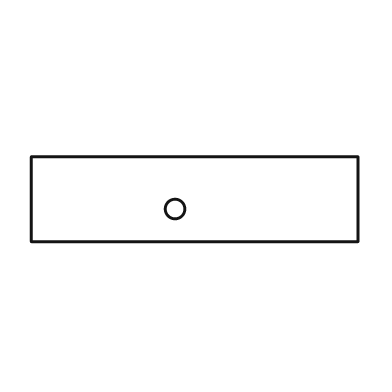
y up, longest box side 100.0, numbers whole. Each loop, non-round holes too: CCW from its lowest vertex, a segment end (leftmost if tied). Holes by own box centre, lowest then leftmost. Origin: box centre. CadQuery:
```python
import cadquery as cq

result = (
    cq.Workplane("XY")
    .moveTo(-50.0, -13.0)
    .lineTo(50.0, -13.0)
    .lineTo(50.0, 13.0)
    .lineTo(-50.0, 13.0)
    .close()
    .moveTo(-6.0, -3.0)
    .circle(3.0)
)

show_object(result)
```